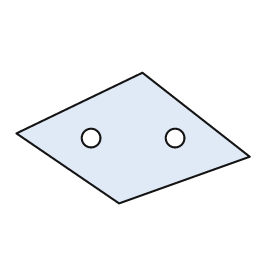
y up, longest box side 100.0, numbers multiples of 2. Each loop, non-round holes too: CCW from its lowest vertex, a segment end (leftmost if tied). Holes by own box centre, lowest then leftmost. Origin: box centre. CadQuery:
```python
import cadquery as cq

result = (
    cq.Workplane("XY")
    .moveTo(-6.0, -28.0)
    .lineTo(50.0, -8.0)
    .lineTo(4.0, 28.0)
    .lineTo(-50.0, 2.0)
    .close()
    .moveTo(-18.0, 0.0)
    .circle(4.0)
    .moveTo(18.0, 0.0)
    .circle(4.0)
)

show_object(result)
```